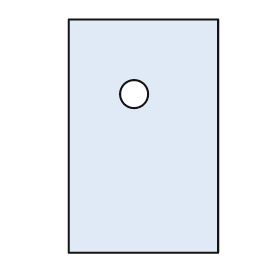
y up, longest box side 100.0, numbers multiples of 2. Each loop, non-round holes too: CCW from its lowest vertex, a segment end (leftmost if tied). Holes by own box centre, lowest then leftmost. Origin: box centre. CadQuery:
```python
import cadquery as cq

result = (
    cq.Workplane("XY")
    .moveTo(-32.0, -50.0)
    .lineTo(32.0, -50.0)
    .lineTo(32.0, 50.0)
    .lineTo(-32.0, 50.0)
    .close()
    .moveTo(-4.0, 18.0)
    .circle(6.0)
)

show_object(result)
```